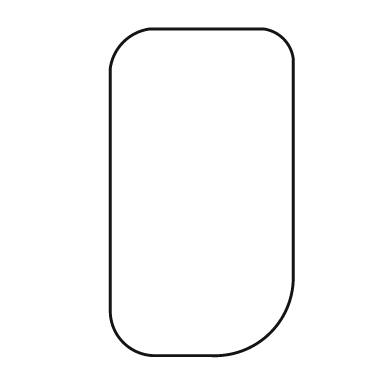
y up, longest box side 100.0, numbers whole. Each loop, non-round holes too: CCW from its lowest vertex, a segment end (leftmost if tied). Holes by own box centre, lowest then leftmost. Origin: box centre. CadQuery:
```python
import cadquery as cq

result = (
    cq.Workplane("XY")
    .moveTo(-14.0, -50.0)
    .lineTo(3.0, -50.0)
    .threePointArc((21.0, -43.0), (28.0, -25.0))
    .lineTo(28.0, 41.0)
    .threePointArc((25.0, 47.0), (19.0, 50.0))
    .lineTo(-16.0, 50.0)
    .threePointArc((-24.0, 46.0), (-28.0, 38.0))
    .lineTo(-28.0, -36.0)
    .threePointArc((-24.0, -46.0), (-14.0, -50.0))
    .close()
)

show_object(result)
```